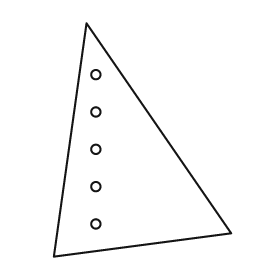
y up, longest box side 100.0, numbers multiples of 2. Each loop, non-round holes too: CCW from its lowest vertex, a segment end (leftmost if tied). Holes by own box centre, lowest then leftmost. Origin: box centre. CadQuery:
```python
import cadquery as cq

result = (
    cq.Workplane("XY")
    .moveTo(-38.0, -50.0)
    .lineTo(38.0, -40.0)
    .lineTo(-24.0, 50.0)
    .close()
    .moveTo(-20.0, -36.0)
    .circle(2.0)
    .moveTo(-20.0, -20.0)
    .circle(2.0)
    .moveTo(-20.0, -4.0)
    .circle(2.0)
    .moveTo(-20.0, 12.0)
    .circle(2.0)
    .moveTo(-20.0, 28.0)
    .circle(2.0)
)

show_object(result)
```